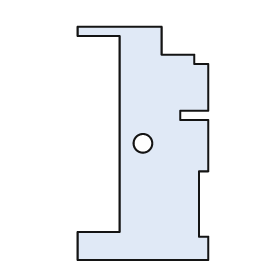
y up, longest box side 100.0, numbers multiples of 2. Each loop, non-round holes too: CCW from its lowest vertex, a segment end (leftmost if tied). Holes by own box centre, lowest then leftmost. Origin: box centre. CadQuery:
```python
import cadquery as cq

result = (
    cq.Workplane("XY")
    .moveTo(-28.0, -50.0)
    .lineTo(28.0, -50.0)
    .lineTo(28.0, -40.0)
    .lineTo(24.0, -40.0)
    .lineTo(24.0, -12.0)
    .lineTo(28.0, -12.0)
    .lineTo(28.0, 10.0)
    .lineTo(16.0, 10.0)
    .lineTo(16.0, 14.0)
    .lineTo(28.0, 14.0)
    .lineTo(28.0, 34.0)
    .lineTo(22.0, 34.0)
    .lineTo(22.0, 38.0)
    .lineTo(8.0, 38.0)
    .lineTo(8.0, 50.0)
    .lineTo(-28.0, 50.0)
    .lineTo(-28.0, 46.0)
    .lineTo(-10.0, 46.0)
    .lineTo(-10.0, -38.0)
    .lineTo(-28.0, -38.0)
    .close()
    .moveTo(0.0, 0.0)
    .circle(4.0)
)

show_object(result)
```